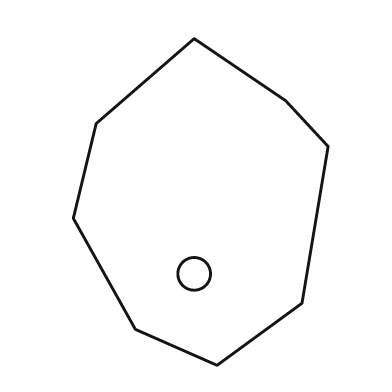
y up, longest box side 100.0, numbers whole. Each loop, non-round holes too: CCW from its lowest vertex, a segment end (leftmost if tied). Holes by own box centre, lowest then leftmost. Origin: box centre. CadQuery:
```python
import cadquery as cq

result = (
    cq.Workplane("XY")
    .moveTo(5.0, -50.0)
    .lineTo(31.0, -31.0)
    .lineTo(39.0, 17.0)
    .lineTo(26.0, 31.0)
    .lineTo(-2.0, 50.0)
    .lineTo(-32.0, 24.0)
    .lineTo(-39.0, -5.0)
    .lineTo(-20.0, -39.0)
    .close()
    .moveTo(-2.0, -22.0)
    .circle(5.0)
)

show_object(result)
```